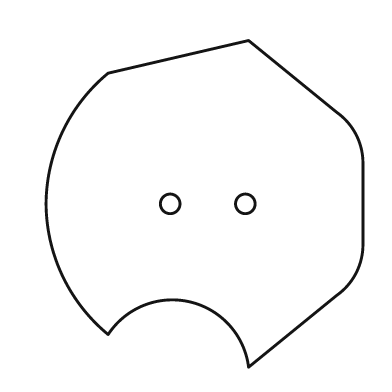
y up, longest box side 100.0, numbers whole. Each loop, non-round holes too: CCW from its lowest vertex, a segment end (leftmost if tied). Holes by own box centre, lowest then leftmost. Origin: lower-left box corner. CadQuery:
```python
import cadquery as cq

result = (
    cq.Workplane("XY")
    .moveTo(62.0, 0.0)
    .lineTo(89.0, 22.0)
    .threePointArc((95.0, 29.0), (97.0, 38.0))
    .lineTo(97.0, 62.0)
    .threePointArc((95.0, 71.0), (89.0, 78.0))
    .lineTo(62.0, 100.0)
    .lineTo(19.0, 90.0)
    .threePointArc((5.0, 72.0), (0.0, 50.0))
    .threePointArc((5.0, 28.0), (19.0, 10.0))
    .threePointArc((44.0, 20.0), (62.0, 0.0))
    .close()
    .moveTo(38.0, 50.0)
    .circle(3.0)
    .moveTo(61.0, 50.0)
    .circle(3.0)
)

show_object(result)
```